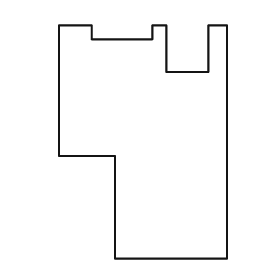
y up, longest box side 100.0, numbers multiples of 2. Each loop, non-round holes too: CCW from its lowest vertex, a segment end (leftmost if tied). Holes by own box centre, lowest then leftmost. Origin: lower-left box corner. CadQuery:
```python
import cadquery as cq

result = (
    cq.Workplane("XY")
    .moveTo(24.0, 0.0)
    .lineTo(72.0, 0.0)
    .lineTo(72.0, 100.0)
    .lineTo(64.0, 100.0)
    .lineTo(64.0, 80.0)
    .lineTo(46.0, 80.0)
    .lineTo(46.0, 100.0)
    .lineTo(40.0, 100.0)
    .lineTo(40.0, 94.0)
    .lineTo(14.0, 94.0)
    .lineTo(14.0, 100.0)
    .lineTo(0.0, 100.0)
    .lineTo(0.0, 44.0)
    .lineTo(24.0, 44.0)
    .close()
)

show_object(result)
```